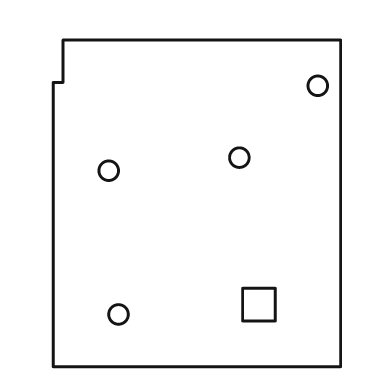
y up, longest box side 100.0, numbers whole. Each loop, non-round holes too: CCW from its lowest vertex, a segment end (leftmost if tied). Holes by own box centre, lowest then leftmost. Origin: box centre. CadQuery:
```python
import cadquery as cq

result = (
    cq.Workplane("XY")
    .moveTo(-44.0, -50.0)
    .lineTo(44.0, -50.0)
    .lineTo(44.0, 50.0)
    .lineTo(-41.0, 50.0)
    .lineTo(-41.0, 37.0)
    .lineTo(-44.0, 37.0)
    .close()
    .moveTo(-24.0, -34.0)
    .circle(3.0)
    .moveTo(14.0, -36.0)
    .lineTo(24.0, -36.0)
    .lineTo(24.0, -26.0)
    .lineTo(14.0, -26.0)
    .close()
    .moveTo(-27.0, 10.0)
    .circle(3.0)
    .moveTo(13.0, 14.0)
    .circle(3.0)
    .moveTo(37.0, 36.0)
    .circle(3.0)
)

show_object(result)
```